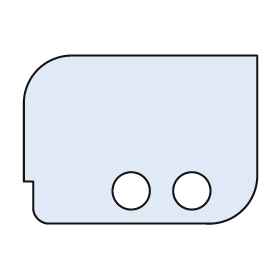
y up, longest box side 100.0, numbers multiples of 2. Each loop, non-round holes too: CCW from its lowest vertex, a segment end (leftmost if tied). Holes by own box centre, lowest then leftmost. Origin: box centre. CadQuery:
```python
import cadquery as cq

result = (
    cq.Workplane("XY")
    .moveTo(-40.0, -36.0)
    .lineTo(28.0, -36.0)
    .threePointArc((44.0, -30.0), (50.0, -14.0))
    .lineTo(50.0, 36.0)
    .lineTo(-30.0, 36.0)
    .threePointArc((-44.0, 30.0), (-50.0, 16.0))
    .lineTo(-50.0, -18.0)
    .lineTo(-46.0, -18.0)
    .lineTo(-46.0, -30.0)
    .threePointArc((-44.0, -34.0), (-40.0, -36.0))
    .close()
    .moveTo(-4.0, -22.0)
    .circle(8.0)
    .moveTo(22.0, -22.0)
    .circle(8.0)
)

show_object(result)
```